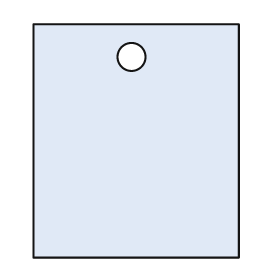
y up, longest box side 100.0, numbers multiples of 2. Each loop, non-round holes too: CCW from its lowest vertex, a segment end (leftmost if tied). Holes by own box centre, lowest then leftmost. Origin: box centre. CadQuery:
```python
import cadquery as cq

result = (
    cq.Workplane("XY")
    .moveTo(-44.0, -50.0)
    .lineTo(44.0, -50.0)
    .lineTo(44.0, 50.0)
    .lineTo(-44.0, 50.0)
    .close()
    .moveTo(-2.0, 36.0)
    .circle(6.0)
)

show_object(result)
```